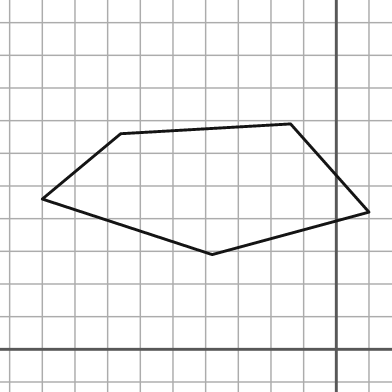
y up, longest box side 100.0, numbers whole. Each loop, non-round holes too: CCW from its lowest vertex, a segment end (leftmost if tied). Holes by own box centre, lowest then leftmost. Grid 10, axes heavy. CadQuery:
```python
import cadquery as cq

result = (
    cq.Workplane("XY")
    .moveTo(-38.0, 29.0)
    .lineTo(10.0, 42.0)
    .lineTo(-14.0, 69.0)
    .lineTo(-66.0, 66.0)
    .lineTo(-90.0, 46.0)
    .close()
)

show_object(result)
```